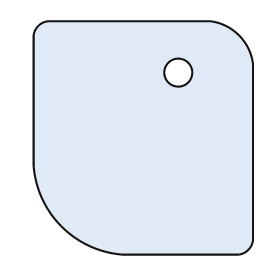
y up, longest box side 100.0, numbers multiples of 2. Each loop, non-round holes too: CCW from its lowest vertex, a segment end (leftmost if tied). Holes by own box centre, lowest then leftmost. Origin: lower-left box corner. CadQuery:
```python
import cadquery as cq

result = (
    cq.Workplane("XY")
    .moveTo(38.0, 0.0)
    .lineTo(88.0, 0.0)
    .threePointArc((92.0, 2.0), (94.0, 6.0))
    .lineTo(94.0, 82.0)
    .threePointArc((88.0, 94.0), (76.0, 100.0))
    .lineTo(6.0, 100.0)
    .threePointArc((2.0, 98.0), (0.0, 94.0))
    .lineTo(0.0, 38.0)
    .threePointArc((12.0, 12.0), (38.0, 0.0))
    .close()
    .moveTo(62.0, 78.0)
    .circle(6.0)
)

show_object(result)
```